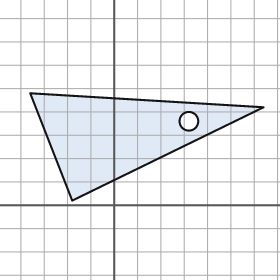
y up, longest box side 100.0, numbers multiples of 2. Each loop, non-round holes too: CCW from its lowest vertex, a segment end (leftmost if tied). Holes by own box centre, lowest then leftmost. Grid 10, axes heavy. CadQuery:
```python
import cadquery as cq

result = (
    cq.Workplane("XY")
    .moveTo(-18.0, 2.0)
    .lineTo(64.0, 42.0)
    .lineTo(-36.0, 48.0)
    .close()
    .moveTo(32.0, 36.0)
    .circle(4.0)
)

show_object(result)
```